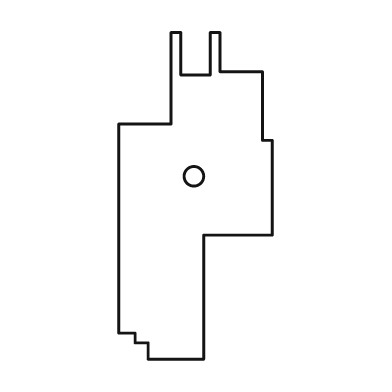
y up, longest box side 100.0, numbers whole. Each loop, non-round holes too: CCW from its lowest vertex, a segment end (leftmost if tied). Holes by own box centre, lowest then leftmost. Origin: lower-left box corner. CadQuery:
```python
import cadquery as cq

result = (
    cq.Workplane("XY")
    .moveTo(9.0, 0.0)
    .lineTo(26.0, 0.0)
    .lineTo(26.0, 38.0)
    .lineTo(47.0, 38.0)
    .lineTo(47.0, 67.0)
    .lineTo(44.0, 67.0)
    .lineTo(44.0, 88.0)
    .lineTo(31.0, 88.0)
    .lineTo(31.0, 100.0)
    .lineTo(28.0, 100.0)
    .lineTo(28.0, 87.0)
    .lineTo(19.0, 87.0)
    .lineTo(19.0, 100.0)
    .lineTo(16.0, 100.0)
    .lineTo(16.0, 72.0)
    .lineTo(0.0, 72.0)
    .lineTo(0.0, 8.0)
    .lineTo(5.0, 8.0)
    .lineTo(5.0, 5.0)
    .lineTo(9.0, 5.0)
    .close()
    .moveTo(23.0, 56.0)
    .circle(3.0)
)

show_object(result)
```